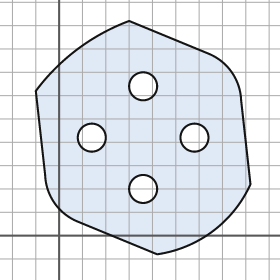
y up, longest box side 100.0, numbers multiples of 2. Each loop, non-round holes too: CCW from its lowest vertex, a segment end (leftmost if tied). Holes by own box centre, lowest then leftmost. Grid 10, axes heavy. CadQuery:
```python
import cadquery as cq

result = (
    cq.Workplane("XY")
    .moveTo(42.0, -8.0)
    .threePointArc((66.0, 2.0), (82.0, 22.0))
    .lineTo(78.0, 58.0)
    .threePointArc((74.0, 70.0), (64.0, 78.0))
    .lineTo(30.0, 92.0)
    .threePointArc((8.0, 80.0), (-10.0, 62.0))
    .lineTo(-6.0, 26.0)
    .threePointArc((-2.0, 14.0), (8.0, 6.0))
    .close()
    .moveTo(36.0, 20.0)
    .circle(6.0)
    .moveTo(14.0, 42.0)
    .circle(6.0)
    .moveTo(58.0, 42.0)
    .circle(6.0)
    .moveTo(36.0, 64.0)
    .circle(6.0)
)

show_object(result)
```